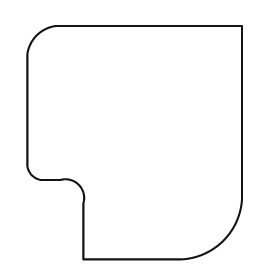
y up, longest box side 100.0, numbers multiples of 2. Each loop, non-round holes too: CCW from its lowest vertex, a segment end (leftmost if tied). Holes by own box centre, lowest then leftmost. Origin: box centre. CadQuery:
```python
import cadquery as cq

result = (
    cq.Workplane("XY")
    .moveTo(-22.0, -50.0)
    .lineTo(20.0, -50.0)
    .threePointArc((38.0, -42.0), (46.0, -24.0))
    .lineTo(46.0, 50.0)
    .lineTo(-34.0, 50.0)
    .threePointArc((-42.0, 46.0), (-46.0, 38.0))
    .lineTo(-46.0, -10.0)
    .threePointArc((-44.0, -14.0), (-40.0, -16.0))
    .lineTo(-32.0, -16.0)
    .threePointArc((-24.0, -18.0), (-22.0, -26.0))
    .close()
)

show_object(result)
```